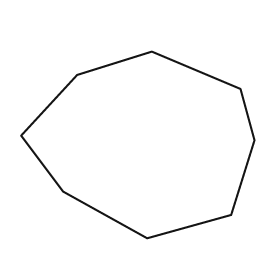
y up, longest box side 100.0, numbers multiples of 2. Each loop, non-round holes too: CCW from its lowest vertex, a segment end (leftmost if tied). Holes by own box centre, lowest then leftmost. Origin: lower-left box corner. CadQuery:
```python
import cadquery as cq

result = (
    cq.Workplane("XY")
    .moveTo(54.0, 0.0)
    .lineTo(90.0, 10.0)
    .lineTo(100.0, 42.0)
    .lineTo(94.0, 64.0)
    .lineTo(56.0, 80.0)
    .lineTo(24.0, 70.0)
    .lineTo(0.0, 44.0)
    .lineTo(18.0, 20.0)
    .close()
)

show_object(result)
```